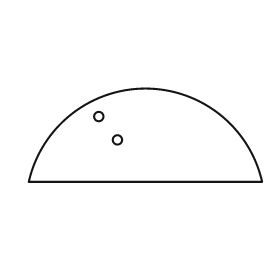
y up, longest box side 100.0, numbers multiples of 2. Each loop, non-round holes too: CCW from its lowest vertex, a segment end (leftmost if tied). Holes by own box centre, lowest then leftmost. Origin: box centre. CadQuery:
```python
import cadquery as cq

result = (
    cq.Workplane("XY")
    .moveTo(-50.0, -20.0)
    .lineTo(50.0, -20.0)
    .threePointArc((0.0, 20.0), (-50.0, -20.0))
    .close()
    .moveTo(-12.0, -2.0)
    .circle(2.0)
    .moveTo(-20.0, 8.0)
    .circle(2.0)
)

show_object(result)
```